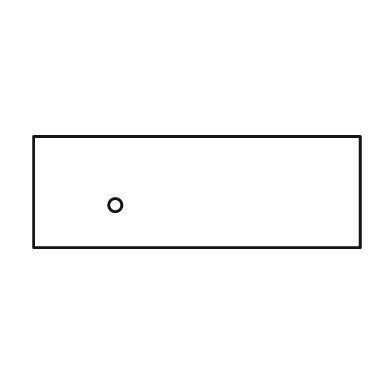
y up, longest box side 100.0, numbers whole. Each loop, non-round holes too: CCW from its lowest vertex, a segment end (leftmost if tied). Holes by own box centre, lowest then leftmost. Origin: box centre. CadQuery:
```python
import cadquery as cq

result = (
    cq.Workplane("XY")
    .moveTo(-50.0, -17.0)
    .lineTo(50.0, -17.0)
    .lineTo(50.0, 17.0)
    .lineTo(-50.0, 17.0)
    .close()
    .moveTo(-25.0, -4.0)
    .circle(2.0)
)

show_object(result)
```